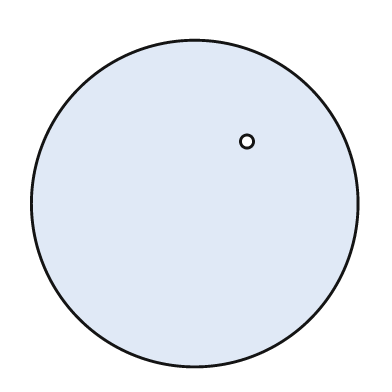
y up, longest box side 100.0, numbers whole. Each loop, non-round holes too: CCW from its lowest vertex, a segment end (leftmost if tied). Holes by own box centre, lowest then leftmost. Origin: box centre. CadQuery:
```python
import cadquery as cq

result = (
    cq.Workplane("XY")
    .moveTo(0.0, 0.0)
    .circle(50.0)
    .moveTo(16.0, 19.0)
    .circle(2.0)
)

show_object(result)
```